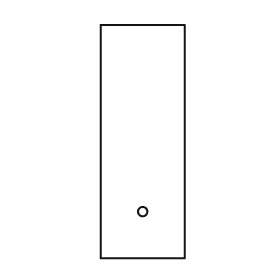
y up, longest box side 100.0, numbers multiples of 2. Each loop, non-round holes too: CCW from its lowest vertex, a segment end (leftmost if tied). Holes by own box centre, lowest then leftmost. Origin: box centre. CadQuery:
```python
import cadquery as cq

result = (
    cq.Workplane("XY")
    .moveTo(-18.0, -50.0)
    .lineTo(18.0, -50.0)
    .lineTo(18.0, 50.0)
    .lineTo(-18.0, 50.0)
    .close()
    .moveTo(0.0, -30.0)
    .circle(2.0)
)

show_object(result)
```